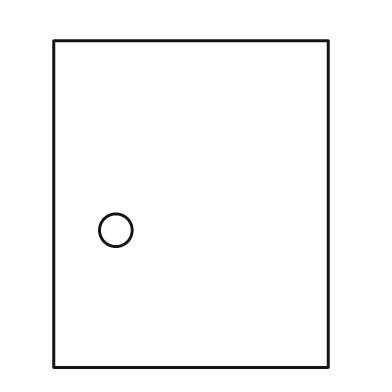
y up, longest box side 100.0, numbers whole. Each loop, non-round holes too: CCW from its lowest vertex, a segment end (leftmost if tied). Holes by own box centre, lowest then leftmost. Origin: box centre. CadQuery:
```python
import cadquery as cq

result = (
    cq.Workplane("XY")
    .moveTo(-42.0, -50.0)
    .lineTo(42.0, -50.0)
    .lineTo(42.0, 50.0)
    .lineTo(-42.0, 50.0)
    .close()
    .moveTo(-23.0, -8.0)
    .circle(5.0)
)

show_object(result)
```